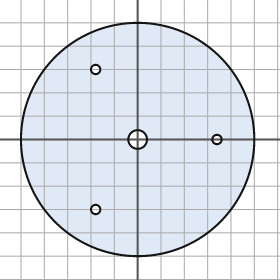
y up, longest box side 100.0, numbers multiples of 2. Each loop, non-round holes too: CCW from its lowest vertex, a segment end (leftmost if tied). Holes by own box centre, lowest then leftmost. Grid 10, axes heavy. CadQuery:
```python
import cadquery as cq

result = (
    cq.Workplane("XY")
    .moveTo(0.0, 0.0)
    .circle(50.0)
    .moveTo(-18.0, -30.0)
    .circle(2.0)
    .moveTo(0.0, 0.0)
    .circle(4.0)
    .moveTo(34.0, 0.0)
    .circle(2.0)
    .moveTo(-18.0, 30.0)
    .circle(2.0)
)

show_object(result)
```